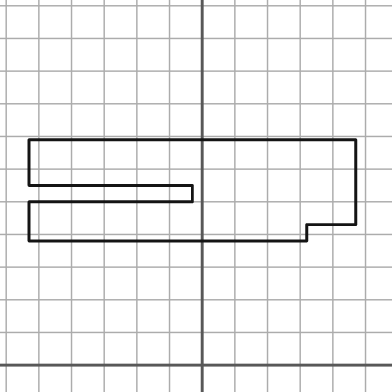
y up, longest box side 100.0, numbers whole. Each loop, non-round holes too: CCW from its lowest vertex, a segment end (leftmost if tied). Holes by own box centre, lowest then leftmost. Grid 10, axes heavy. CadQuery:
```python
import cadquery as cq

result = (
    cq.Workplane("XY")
    .moveTo(-53.0, 38.0)
    .lineTo(32.0, 38.0)
    .lineTo(32.0, 43.0)
    .lineTo(47.0, 43.0)
    .lineTo(47.0, 69.0)
    .lineTo(-53.0, 69.0)
    .lineTo(-53.0, 55.0)
    .lineTo(-3.0, 55.0)
    .lineTo(-3.0, 50.0)
    .lineTo(-53.0, 50.0)
    .close()
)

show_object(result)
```